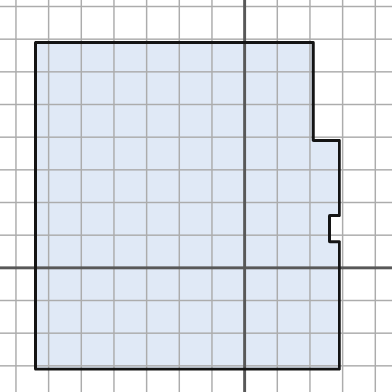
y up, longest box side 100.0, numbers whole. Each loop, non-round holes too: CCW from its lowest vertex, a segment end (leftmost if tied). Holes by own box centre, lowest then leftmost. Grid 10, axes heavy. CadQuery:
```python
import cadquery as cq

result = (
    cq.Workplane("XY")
    .moveTo(-64.0, -31.0)
    .lineTo(29.0, -31.0)
    .lineTo(29.0, 8.0)
    .lineTo(26.0, 8.0)
    .lineTo(26.0, 16.0)
    .lineTo(29.0, 16.0)
    .lineTo(29.0, 39.0)
    .lineTo(21.0, 39.0)
    .lineTo(21.0, 69.0)
    .lineTo(-64.0, 69.0)
    .close()
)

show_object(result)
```